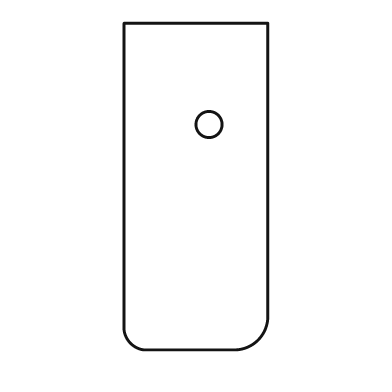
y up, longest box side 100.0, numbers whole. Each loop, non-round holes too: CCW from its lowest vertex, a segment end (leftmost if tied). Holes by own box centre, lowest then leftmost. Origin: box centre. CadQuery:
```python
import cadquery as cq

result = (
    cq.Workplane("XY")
    .moveTo(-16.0, -50.0)
    .lineTo(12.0, -50.0)
    .threePointArc((19.0, -47.0), (22.0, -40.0))
    .lineTo(22.0, 50.0)
    .lineTo(-22.0, 50.0)
    .lineTo(-22.0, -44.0)
    .threePointArc((-20.0, -48.0), (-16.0, -50.0))
    .close()
    .moveTo(4.0, 19.0)
    .circle(4.0)
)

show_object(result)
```